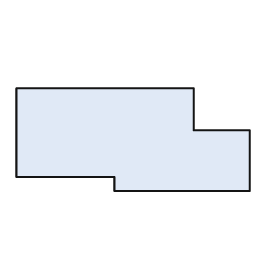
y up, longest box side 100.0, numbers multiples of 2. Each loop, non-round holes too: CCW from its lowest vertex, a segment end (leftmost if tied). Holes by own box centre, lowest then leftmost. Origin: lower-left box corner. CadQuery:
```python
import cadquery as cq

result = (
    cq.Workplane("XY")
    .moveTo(42.0, 0.0)
    .lineTo(100.0, 0.0)
    .lineTo(100.0, 26.0)
    .lineTo(76.0, 26.0)
    .lineTo(76.0, 44.0)
    .lineTo(0.0, 44.0)
    .lineTo(0.0, 6.0)
    .lineTo(42.0, 6.0)
    .close()
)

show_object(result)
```